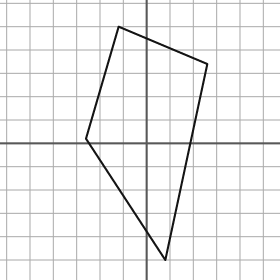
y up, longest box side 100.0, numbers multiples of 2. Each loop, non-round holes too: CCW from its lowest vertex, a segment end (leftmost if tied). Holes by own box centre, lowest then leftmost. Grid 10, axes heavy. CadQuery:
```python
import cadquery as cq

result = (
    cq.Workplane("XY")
    .moveTo(8.0, -50.0)
    .lineTo(26.0, 34.0)
    .lineTo(-12.0, 50.0)
    .lineTo(-26.0, 2.0)
    .close()
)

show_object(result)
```